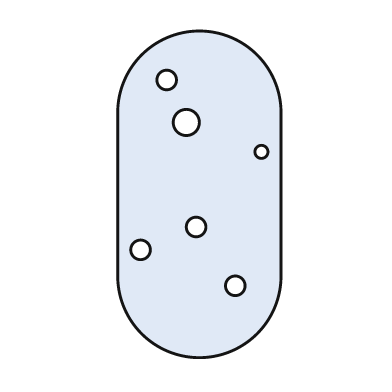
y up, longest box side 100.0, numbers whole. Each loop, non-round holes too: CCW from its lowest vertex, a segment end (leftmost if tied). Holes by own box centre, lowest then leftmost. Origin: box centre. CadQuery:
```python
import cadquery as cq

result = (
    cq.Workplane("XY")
    .moveTo(-25.0, -25.0)
    .threePointArc((0.0, -50.0), (25.0, -25.0))
    .lineTo(25.0, 25.0)
    .threePointArc((0.0, 50.0), (-25.0, 25.0))
    .close()
    .moveTo(11.0, -28.0)
    .circle(3.0)
    .moveTo(-18.0, -17.0)
    .circle(3.0)
    .moveTo(-1.0, -10.0)
    .circle(3.0)
    .moveTo(19.0, 13.0)
    .circle(2.0)
    .moveTo(-4.0, 22.0)
    .circle(4.0)
    .moveTo(-10.0, 35.0)
    .circle(3.0)
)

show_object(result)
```